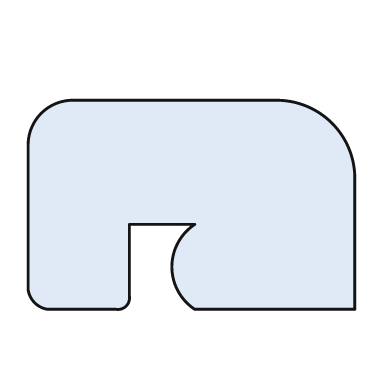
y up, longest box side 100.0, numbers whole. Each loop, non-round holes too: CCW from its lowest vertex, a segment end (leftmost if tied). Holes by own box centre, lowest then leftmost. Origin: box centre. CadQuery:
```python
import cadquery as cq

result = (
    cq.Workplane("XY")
    .moveTo(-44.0, -32.0)
    .lineTo(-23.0, -32.0)
    .threePointArc((-20.0, -31.0), (-19.0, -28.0))
    .lineTo(-19.0, -6.0)
    .lineTo(1.0, -6.0)
    .threePointArc((-6.0, -19.0), (1.0, -32.0))
    .lineTo(50.0, -32.0)
    .lineTo(50.0, 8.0)
    .threePointArc((43.0, 25.0), (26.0, 32.0))
    .lineTo(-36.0, 32.0)
    .threePointArc((-46.0, 28.0), (-50.0, 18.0))
    .lineTo(-50.0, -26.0)
    .threePointArc((-48.0, -30.0), (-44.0, -32.0))
    .close()
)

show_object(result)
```